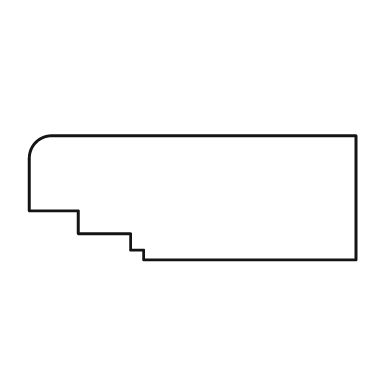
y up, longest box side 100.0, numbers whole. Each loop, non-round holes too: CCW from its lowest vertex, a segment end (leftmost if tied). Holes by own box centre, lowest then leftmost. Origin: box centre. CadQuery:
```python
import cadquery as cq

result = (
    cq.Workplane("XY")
    .moveTo(-15.0, -19.0)
    .lineTo(50.0, -19.0)
    .lineTo(50.0, 19.0)
    .lineTo(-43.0, 19.0)
    .threePointArc((-48.0, 17.0), (-50.0, 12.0))
    .lineTo(-50.0, -4.0)
    .lineTo(-35.0, -4.0)
    .lineTo(-35.0, -11.0)
    .lineTo(-19.0, -11.0)
    .lineTo(-19.0, -16.0)
    .lineTo(-15.0, -16.0)
    .close()
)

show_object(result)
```